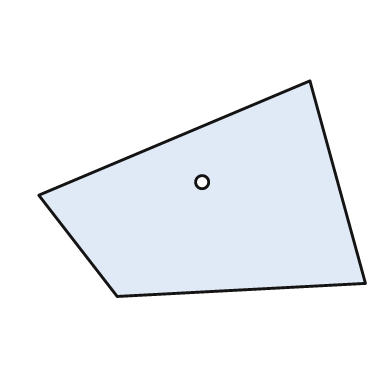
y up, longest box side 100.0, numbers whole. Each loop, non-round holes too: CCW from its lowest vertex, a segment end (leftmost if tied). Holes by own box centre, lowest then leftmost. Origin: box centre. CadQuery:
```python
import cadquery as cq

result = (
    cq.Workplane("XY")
    .moveTo(-26.0, -33.0)
    .lineTo(50.0, -29.0)
    .lineTo(33.0, 33.0)
    .lineTo(-50.0, -2.0)
    .close()
    .moveTo(0.0, 2.0)
    .circle(2.0)
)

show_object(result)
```